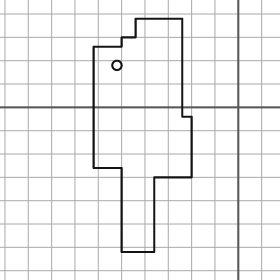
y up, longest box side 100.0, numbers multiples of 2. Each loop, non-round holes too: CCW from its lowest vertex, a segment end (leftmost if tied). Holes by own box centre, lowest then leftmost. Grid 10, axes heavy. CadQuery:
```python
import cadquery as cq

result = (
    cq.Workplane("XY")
    .moveTo(-50.0, -62.0)
    .lineTo(-36.0, -62.0)
    .lineTo(-36.0, -30.0)
    .lineTo(-20.0, -30.0)
    .lineTo(-20.0, -4.0)
    .lineTo(-24.0, -4.0)
    .lineTo(-24.0, 38.0)
    .lineTo(-44.0, 38.0)
    .lineTo(-44.0, 30.0)
    .lineTo(-50.0, 30.0)
    .lineTo(-50.0, 26.0)
    .lineTo(-62.0, 26.0)
    .lineTo(-62.0, -26.0)
    .lineTo(-50.0, -26.0)
    .close()
    .moveTo(-52.0, 18.0)
    .circle(2.0)
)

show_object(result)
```